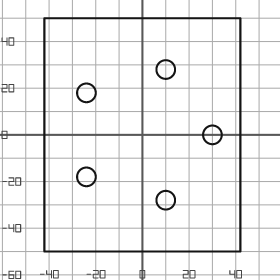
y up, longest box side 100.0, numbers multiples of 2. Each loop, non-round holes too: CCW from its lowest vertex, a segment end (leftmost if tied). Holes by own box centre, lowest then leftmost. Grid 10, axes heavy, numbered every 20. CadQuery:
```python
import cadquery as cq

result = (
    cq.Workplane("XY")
    .moveTo(-42.0, -50.0)
    .lineTo(42.0, -50.0)
    .lineTo(42.0, 50.0)
    .lineTo(-42.0, 50.0)
    .close()
    .moveTo(10.0, -28.0)
    .circle(4.0)
    .moveTo(-24.0, -18.0)
    .circle(4.0)
    .moveTo(30.0, 0.0)
    .circle(4.0)
    .moveTo(-24.0, 18.0)
    .circle(4.0)
    .moveTo(10.0, 28.0)
    .circle(4.0)
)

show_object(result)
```